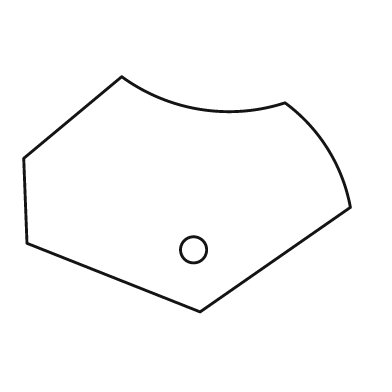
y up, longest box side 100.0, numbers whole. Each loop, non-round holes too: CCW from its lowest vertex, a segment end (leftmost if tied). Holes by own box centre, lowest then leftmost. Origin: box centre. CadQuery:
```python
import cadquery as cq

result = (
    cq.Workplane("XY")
    .moveTo(4.0, -36.0)
    .lineTo(50.0, -4.0)
    .threePointArc((43.0, 14.0), (30.0, 28.0))
    .threePointArc((4.0, 26.0), (-20.0, 36.0))
    .lineTo(-50.0, 11.0)
    .lineTo(-49.0, -15.0)
    .close()
    .moveTo(2.0, -17.0)
    .circle(4.0)
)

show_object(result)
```